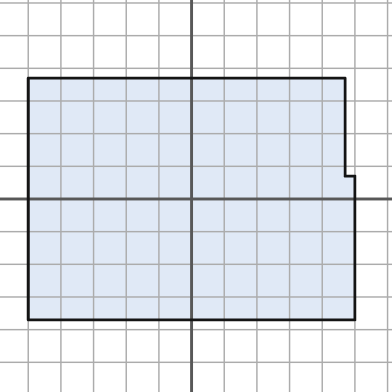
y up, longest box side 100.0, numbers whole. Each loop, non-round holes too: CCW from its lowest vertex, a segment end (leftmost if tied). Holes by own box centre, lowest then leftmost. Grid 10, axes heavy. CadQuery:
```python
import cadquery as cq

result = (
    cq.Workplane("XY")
    .moveTo(-50.0, -37.0)
    .lineTo(50.0, -37.0)
    .lineTo(50.0, 7.0)
    .lineTo(47.0, 7.0)
    .lineTo(47.0, 37.0)
    .lineTo(-50.0, 37.0)
    .close()
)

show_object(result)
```